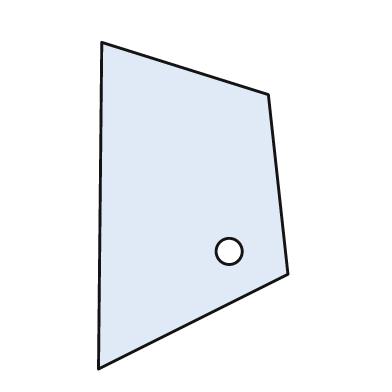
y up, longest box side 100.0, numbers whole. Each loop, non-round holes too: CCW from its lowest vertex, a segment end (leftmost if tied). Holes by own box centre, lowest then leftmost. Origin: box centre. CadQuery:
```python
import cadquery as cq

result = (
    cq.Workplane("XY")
    .moveTo(-29.0, -50.0)
    .lineTo(29.0, -21.0)
    .lineTo(23.0, 34.0)
    .lineTo(-28.0, 50.0)
    .close()
    .moveTo(11.0, -14.0)
    .circle(4.0)
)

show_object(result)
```